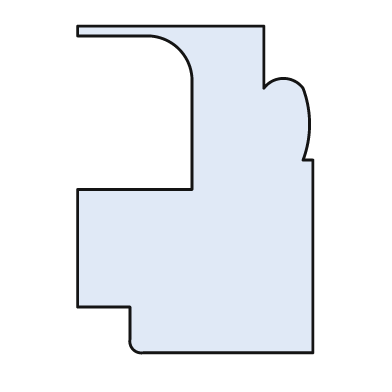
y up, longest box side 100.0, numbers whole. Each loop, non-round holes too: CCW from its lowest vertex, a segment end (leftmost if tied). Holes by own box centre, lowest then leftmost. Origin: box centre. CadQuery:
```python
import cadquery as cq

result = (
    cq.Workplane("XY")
    .moveTo(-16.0, -50.0)
    .lineTo(36.0, -50.0)
    .lineTo(36.0, 9.0)
    .lineTo(33.0, 9.0)
    .threePointArc((35.0, 20.0), (33.0, 31.0))
    .threePointArc((27.0, 34.0), (21.0, 31.0))
    .lineTo(21.0, 50.0)
    .lineTo(-36.0, 50.0)
    .lineTo(-36.0, 47.0)
    .lineTo(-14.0, 47.0)
    .threePointArc((-5.0, 43.0), (-1.0, 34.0))
    .lineTo(-1.0, 0.0)
    .lineTo(-36.0, 0.0)
    .lineTo(-36.0, -36.0)
    .lineTo(-20.0, -36.0)
    .lineTo(-20.0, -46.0)
    .threePointArc((-19.0, -49.0), (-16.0, -50.0))
    .close()
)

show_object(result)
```